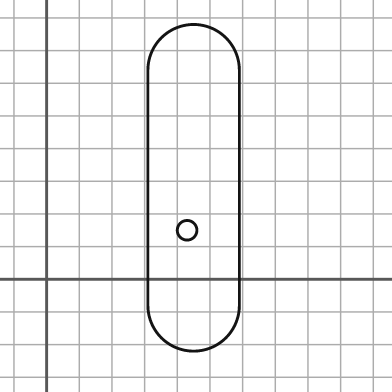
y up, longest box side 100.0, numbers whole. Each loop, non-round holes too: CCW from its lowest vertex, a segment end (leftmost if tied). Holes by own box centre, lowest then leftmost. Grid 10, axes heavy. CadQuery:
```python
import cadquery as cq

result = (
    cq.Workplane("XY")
    .moveTo(31.0, -8.0)
    .threePointArc((45.0, -22.0), (59.0, -8.0))
    .lineTo(59.0, 64.0)
    .threePointArc((45.0, 78.0), (31.0, 64.0))
    .close()
    .moveTo(43.0, 15.0)
    .circle(3.0)
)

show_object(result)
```